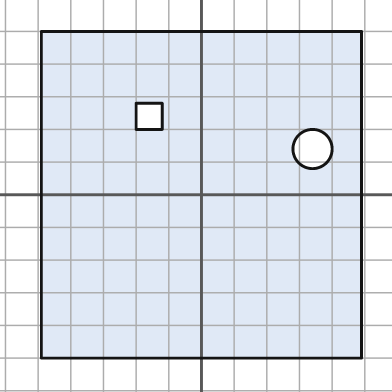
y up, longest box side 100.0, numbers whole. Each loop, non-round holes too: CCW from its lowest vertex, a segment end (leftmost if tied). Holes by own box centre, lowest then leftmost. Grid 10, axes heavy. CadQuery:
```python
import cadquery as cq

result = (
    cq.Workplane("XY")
    .moveTo(-49.0, -50.0)
    .lineTo(49.0, -50.0)
    .lineTo(49.0, 50.0)
    .lineTo(-49.0, 50.0)
    .close()
    .moveTo(34.0, 14.0)
    .circle(6.0)
    .moveTo(-20.0, 20.0)
    .lineTo(-12.0, 20.0)
    .lineTo(-12.0, 28.0)
    .lineTo(-20.0, 28.0)
    .close()
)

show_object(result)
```